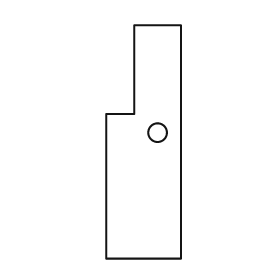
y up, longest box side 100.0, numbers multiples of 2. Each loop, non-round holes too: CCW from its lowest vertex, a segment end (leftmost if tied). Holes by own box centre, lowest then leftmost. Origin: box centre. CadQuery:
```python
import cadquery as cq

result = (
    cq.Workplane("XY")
    .moveTo(-16.0, -50.0)
    .lineTo(16.0, -50.0)
    .lineTo(16.0, 50.0)
    .lineTo(-4.0, 50.0)
    .lineTo(-4.0, 12.0)
    .lineTo(-16.0, 12.0)
    .close()
    .moveTo(6.0, 4.0)
    .circle(4.0)
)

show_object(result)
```